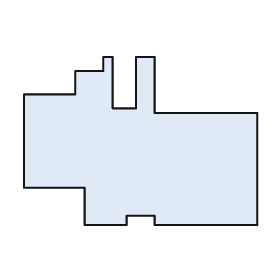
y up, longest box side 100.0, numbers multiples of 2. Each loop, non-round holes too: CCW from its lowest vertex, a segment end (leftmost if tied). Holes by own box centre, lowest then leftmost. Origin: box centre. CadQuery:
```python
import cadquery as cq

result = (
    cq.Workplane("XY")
    .moveTo(-24.0, -36.0)
    .lineTo(-6.0, -36.0)
    .lineTo(-6.0, -32.0)
    .lineTo(6.0, -32.0)
    .lineTo(6.0, -36.0)
    .lineTo(50.0, -36.0)
    .lineTo(50.0, 12.0)
    .lineTo(6.0, 12.0)
    .lineTo(6.0, 36.0)
    .lineTo(-2.0, 36.0)
    .lineTo(-2.0, 14.0)
    .lineTo(-12.0, 14.0)
    .lineTo(-12.0, 36.0)
    .lineTo(-16.0, 36.0)
    .lineTo(-16.0, 30.0)
    .lineTo(-28.0, 30.0)
    .lineTo(-28.0, 20.0)
    .lineTo(-50.0, 20.0)
    .lineTo(-50.0, -20.0)
    .lineTo(-24.0, -20.0)
    .close()
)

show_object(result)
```